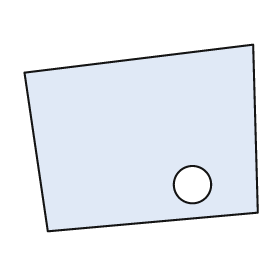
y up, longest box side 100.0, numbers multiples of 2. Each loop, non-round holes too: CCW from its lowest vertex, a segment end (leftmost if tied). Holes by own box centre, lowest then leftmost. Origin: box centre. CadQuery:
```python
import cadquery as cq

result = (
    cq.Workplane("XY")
    .moveTo(-40.0, -40.0)
    .lineTo(50.0, -32.0)
    .lineTo(48.0, 40.0)
    .lineTo(-50.0, 28.0)
    .close()
    .moveTo(22.0, -20.0)
    .circle(8.0)
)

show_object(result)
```